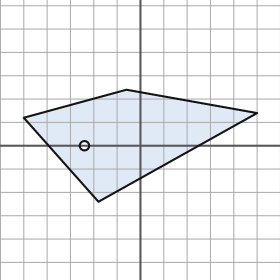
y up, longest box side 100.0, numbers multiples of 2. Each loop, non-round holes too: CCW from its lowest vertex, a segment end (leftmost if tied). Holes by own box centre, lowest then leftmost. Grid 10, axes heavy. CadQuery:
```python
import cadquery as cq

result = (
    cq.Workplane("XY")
    .moveTo(-18.0, -24.0)
    .lineTo(50.0, 14.0)
    .lineTo(-6.0, 24.0)
    .lineTo(-50.0, 12.0)
    .close()
    .moveTo(-24.0, 0.0)
    .circle(2.0)
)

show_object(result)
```